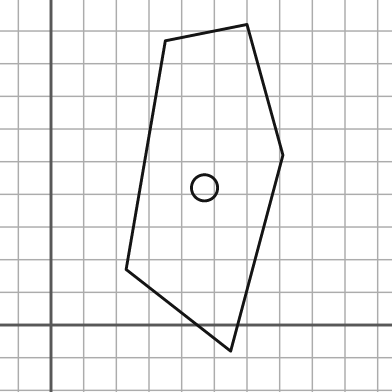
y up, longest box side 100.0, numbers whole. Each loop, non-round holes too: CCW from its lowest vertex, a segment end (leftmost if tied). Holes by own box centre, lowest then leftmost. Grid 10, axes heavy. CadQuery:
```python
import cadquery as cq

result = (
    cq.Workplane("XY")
    .moveTo(55.0, -8.0)
    .lineTo(71.0, 52.0)
    .lineTo(60.0, 92.0)
    .lineTo(35.0, 87.0)
    .lineTo(23.0, 17.0)
    .close()
    .moveTo(47.0, 42.0)
    .circle(4.0)
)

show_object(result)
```